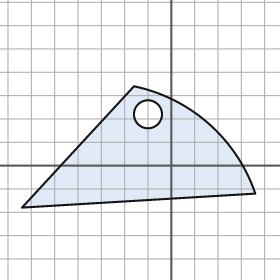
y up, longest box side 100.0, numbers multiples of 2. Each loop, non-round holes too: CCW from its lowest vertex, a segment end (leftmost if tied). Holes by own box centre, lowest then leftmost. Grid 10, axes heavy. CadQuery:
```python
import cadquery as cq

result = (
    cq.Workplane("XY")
    .moveTo(-64.0, -18.0)
    .lineTo(36.0, -12.0)
    .threePointArc((16.0, 18.0), (-16.0, 34.0))
    .close()
    .moveTo(-10.0, 22.0)
    .circle(6.0)
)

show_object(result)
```